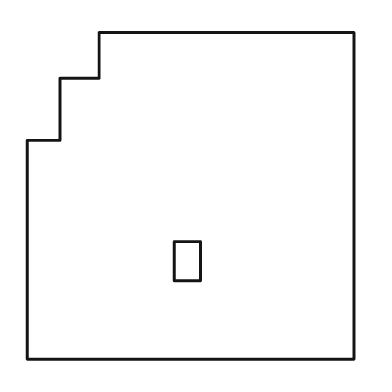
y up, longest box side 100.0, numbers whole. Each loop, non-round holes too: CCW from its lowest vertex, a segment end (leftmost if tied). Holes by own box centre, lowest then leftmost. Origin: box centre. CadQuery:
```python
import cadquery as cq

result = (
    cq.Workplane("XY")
    .moveTo(-50.0, -50.0)
    .lineTo(50.0, -50.0)
    .lineTo(50.0, 50.0)
    .lineTo(-28.0, 50.0)
    .lineTo(-28.0, 36.0)
    .lineTo(-40.0, 36.0)
    .lineTo(-40.0, 17.0)
    .lineTo(-50.0, 17.0)
    .close()
    .moveTo(-5.0, -26.0)
    .lineTo(3.0, -26.0)
    .lineTo(3.0, -14.0)
    .lineTo(-5.0, -14.0)
    .close()
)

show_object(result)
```